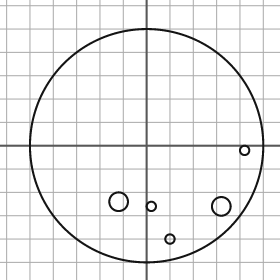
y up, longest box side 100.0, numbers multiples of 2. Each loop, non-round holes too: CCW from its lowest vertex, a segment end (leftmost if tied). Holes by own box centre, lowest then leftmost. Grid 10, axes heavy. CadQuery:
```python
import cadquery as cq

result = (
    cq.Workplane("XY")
    .moveTo(0.0, 0.0)
    .circle(50.0)
    .moveTo(10.0, -40.0)
    .circle(2.0)
    .moveTo(2.0, -26.0)
    .circle(2.0)
    .moveTo(32.0, -26.0)
    .circle(4.0)
    .moveTo(-12.0, -24.0)
    .circle(4.0)
    .moveTo(42.0, -2.0)
    .circle(2.0)
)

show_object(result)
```